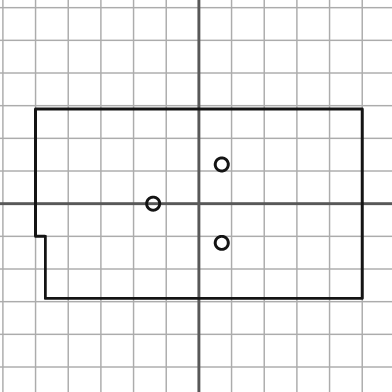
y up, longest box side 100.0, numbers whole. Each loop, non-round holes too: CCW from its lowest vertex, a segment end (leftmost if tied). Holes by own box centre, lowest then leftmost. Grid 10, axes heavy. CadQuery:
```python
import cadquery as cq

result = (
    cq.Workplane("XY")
    .moveTo(-47.0, -29.0)
    .lineTo(50.0, -29.0)
    .lineTo(50.0, 29.0)
    .lineTo(-50.0, 29.0)
    .lineTo(-50.0, -10.0)
    .lineTo(-47.0, -10.0)
    .close()
    .moveTo(7.0, -12.0)
    .circle(2.0)
    .moveTo(-14.0, 0.0)
    .circle(2.0)
    .moveTo(7.0, 12.0)
    .circle(2.0)
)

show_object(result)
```